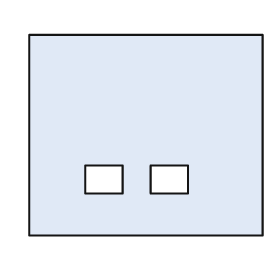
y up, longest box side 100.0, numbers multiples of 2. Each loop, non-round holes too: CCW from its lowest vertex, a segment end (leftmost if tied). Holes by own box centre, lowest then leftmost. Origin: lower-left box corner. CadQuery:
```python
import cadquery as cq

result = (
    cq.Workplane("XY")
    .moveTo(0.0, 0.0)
    .lineTo(100.0, 0.0)
    .lineTo(100.0, 86.0)
    .lineTo(0.0, 86.0)
    .close()
    .moveTo(24.0, 18.0)
    .lineTo(40.0, 18.0)
    .lineTo(40.0, 30.0)
    .lineTo(24.0, 30.0)
    .close()
    .moveTo(52.0, 18.0)
    .lineTo(68.0, 18.0)
    .lineTo(68.0, 30.0)
    .lineTo(52.0, 30.0)
    .close()
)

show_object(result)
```